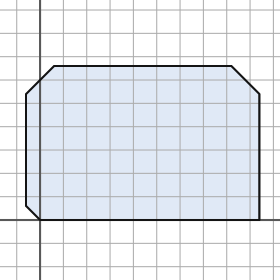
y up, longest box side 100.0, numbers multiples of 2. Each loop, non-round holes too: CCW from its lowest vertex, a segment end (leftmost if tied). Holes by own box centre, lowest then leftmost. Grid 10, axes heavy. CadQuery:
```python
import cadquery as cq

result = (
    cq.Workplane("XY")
    .moveTo(0.0, 0.0)
    .lineTo(94.0, 0.0)
    .lineTo(94.0, 54.0)
    .lineTo(82.0, 66.0)
    .lineTo(6.0, 66.0)
    .lineTo(-6.0, 54.0)
    .lineTo(-6.0, 6.0)
    .close()
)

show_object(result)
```